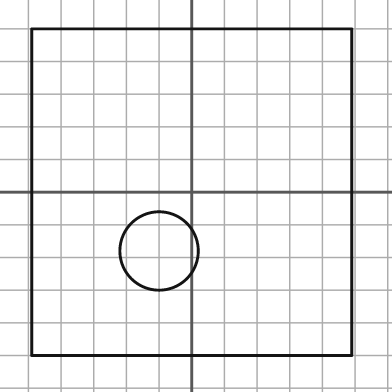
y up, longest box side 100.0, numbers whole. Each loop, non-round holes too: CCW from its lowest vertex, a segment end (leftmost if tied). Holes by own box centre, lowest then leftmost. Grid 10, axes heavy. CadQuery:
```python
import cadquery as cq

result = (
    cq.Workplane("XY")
    .moveTo(-49.0, -50.0)
    .lineTo(49.0, -50.0)
    .lineTo(49.0, 50.0)
    .lineTo(-49.0, 50.0)
    .close()
    .moveTo(-10.0, -18.0)
    .circle(12.0)
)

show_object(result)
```